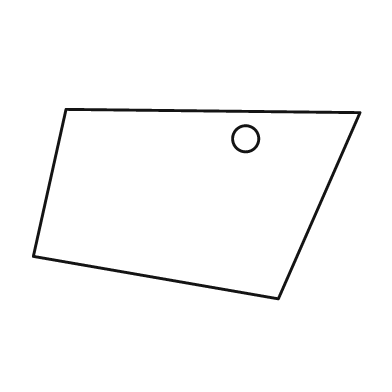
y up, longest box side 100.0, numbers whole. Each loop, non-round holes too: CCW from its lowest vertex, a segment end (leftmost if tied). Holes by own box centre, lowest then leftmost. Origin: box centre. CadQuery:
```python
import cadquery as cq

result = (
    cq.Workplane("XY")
    .moveTo(25.0, -29.0)
    .lineTo(50.0, 28.0)
    .lineTo(-40.0, 29.0)
    .lineTo(-50.0, -16.0)
    .close()
    .moveTo(15.0, 20.0)
    .circle(4.0)
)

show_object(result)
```